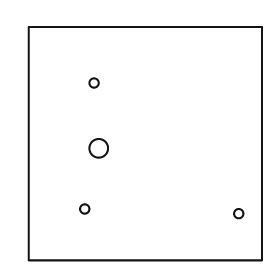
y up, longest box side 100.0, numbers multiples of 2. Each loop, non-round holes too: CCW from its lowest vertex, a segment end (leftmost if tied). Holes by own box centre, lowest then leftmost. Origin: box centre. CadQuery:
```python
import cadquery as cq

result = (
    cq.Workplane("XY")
    .moveTo(-50.0, -50.0)
    .lineTo(50.0, -50.0)
    .lineTo(50.0, 50.0)
    .lineTo(-50.0, 50.0)
    .close()
    .moveTo(40.0, -30.0)
    .circle(2.0)
    .moveTo(-26.0, -28.0)
    .circle(2.0)
    .moveTo(-20.0, -2.0)
    .circle(4.0)
    .moveTo(-22.0, 26.0)
    .circle(2.0)
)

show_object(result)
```